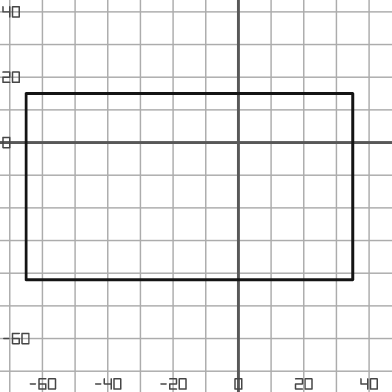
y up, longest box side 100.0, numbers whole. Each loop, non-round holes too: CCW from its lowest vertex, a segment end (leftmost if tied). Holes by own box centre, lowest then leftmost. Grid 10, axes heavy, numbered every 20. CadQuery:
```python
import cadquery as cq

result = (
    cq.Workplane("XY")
    .moveTo(-65.0, -42.0)
    .lineTo(35.0, -42.0)
    .lineTo(35.0, 15.0)
    .lineTo(-65.0, 15.0)
    .close()
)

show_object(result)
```